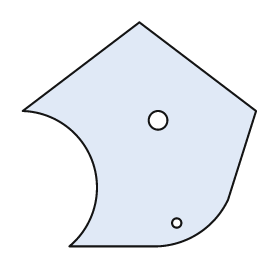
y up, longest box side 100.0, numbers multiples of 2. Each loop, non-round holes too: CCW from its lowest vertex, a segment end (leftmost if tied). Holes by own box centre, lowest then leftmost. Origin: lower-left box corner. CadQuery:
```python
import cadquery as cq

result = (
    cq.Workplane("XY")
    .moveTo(20.0, 0.0)
    .lineTo(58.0, 0.0)
    .threePointArc((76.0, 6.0), (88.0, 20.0))
    .lineTo(100.0, 58.0)
    .lineTo(50.0, 96.0)
    .lineTo(0.0, 58.0)
    .threePointArc((30.0, 36.0), (20.0, 0.0))
    .close()
    .moveTo(66.0, 10.0)
    .circle(2.0)
    .moveTo(58.0, 54.0)
    .circle(4.0)
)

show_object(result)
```